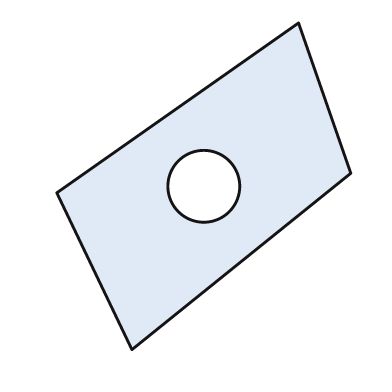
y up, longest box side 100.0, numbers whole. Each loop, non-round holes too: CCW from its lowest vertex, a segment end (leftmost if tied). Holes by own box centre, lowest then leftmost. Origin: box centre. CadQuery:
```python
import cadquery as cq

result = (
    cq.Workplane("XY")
    .moveTo(-22.0, -50.0)
    .lineTo(45.0, 4.0)
    .lineTo(29.0, 50.0)
    .lineTo(-45.0, -2.0)
    .close()
    .moveTo(0.0, 0.0)
    .circle(11.0)
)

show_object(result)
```